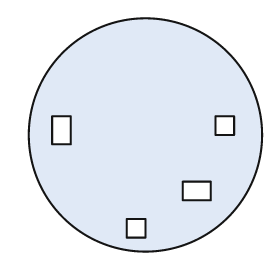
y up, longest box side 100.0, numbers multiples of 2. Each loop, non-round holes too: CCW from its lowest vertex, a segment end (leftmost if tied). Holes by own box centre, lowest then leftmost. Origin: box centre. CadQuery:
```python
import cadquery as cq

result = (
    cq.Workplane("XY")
    .moveTo(0.0, 0.0)
    .circle(50.0)
    .moveTo(-8.0, -44.0)
    .lineTo(0.0, -44.0)
    .lineTo(0.0, -36.0)
    .lineTo(-8.0, -36.0)
    .close()
    .moveTo(16.0, -28.0)
    .lineTo(28.0, -28.0)
    .lineTo(28.0, -20.0)
    .lineTo(16.0, -20.0)
    .close()
    .moveTo(-40.0, -4.0)
    .lineTo(-32.0, -4.0)
    .lineTo(-32.0, 8.0)
    .lineTo(-40.0, 8.0)
    .close()
    .moveTo(30.0, 0.0)
    .lineTo(38.0, 0.0)
    .lineTo(38.0, 8.0)
    .lineTo(30.0, 8.0)
    .close()
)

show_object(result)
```